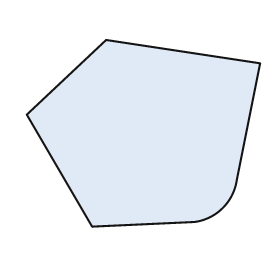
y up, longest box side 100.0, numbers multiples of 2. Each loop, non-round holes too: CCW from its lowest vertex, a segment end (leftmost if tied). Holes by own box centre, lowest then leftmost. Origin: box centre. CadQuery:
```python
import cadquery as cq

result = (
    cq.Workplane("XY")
    .moveTo(-22.0, -40.0)
    .lineTo(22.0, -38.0)
    .threePointArc((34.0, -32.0), (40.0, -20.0))
    .lineTo(50.0, 30.0)
    .lineTo(-16.0, 40.0)
    .lineTo(-50.0, 8.0)
    .close()
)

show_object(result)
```